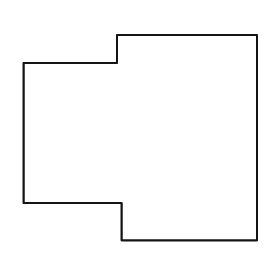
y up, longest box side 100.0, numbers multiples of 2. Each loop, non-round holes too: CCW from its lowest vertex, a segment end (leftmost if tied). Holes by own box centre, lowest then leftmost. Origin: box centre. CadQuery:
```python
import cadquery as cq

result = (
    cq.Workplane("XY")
    .moveTo(-8.0, -44.0)
    .lineTo(50.0, -44.0)
    .lineTo(50.0, 44.0)
    .lineTo(-10.0, 44.0)
    .lineTo(-10.0, 32.0)
    .lineTo(-50.0, 32.0)
    .lineTo(-50.0, -28.0)
    .lineTo(-8.0, -28.0)
    .close()
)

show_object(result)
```